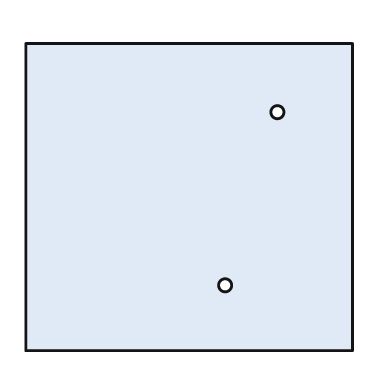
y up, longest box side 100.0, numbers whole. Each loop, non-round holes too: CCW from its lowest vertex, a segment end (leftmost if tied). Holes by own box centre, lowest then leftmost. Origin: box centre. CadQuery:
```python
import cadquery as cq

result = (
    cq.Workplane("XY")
    .moveTo(-50.0, -47.0)
    .lineTo(50.0, -47.0)
    .lineTo(50.0, 47.0)
    .lineTo(-50.0, 47.0)
    .close()
    .moveTo(11.0, -27.0)
    .circle(2.0)
    .moveTo(27.0, 26.0)
    .circle(2.0)
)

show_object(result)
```